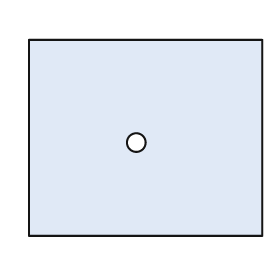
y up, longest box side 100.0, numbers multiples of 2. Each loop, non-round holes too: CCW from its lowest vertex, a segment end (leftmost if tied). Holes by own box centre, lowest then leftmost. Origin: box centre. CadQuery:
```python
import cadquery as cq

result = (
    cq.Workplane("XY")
    .moveTo(-50.0, -42.0)
    .lineTo(50.0, -42.0)
    .lineTo(50.0, 42.0)
    .lineTo(-50.0, 42.0)
    .close()
    .moveTo(-4.0, -2.0)
    .circle(4.0)
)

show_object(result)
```